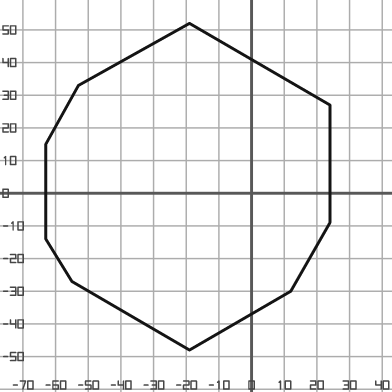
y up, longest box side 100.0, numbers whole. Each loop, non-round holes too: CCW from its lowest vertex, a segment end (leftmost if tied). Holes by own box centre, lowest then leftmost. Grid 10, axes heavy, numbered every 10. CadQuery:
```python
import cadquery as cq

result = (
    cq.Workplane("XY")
    .moveTo(-19.0, -48.0)
    .lineTo(12.0, -30.0)
    .lineTo(24.0, -9.0)
    .lineTo(24.0, 27.0)
    .lineTo(-19.0, 52.0)
    .lineTo(-53.0, 33.0)
    .lineTo(-63.0, 15.0)
    .lineTo(-63.0, -14.0)
    .lineTo(-55.0, -27.0)
    .close()
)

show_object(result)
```